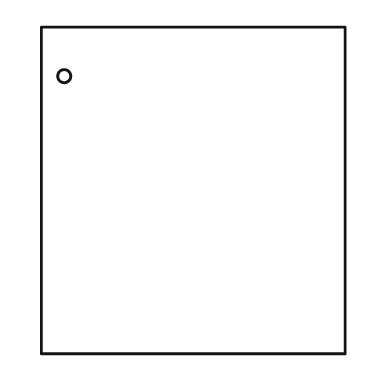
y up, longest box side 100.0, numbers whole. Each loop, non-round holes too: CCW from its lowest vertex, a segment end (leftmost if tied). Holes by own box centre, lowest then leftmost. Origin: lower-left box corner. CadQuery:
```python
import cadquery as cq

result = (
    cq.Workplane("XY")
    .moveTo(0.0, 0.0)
    .lineTo(93.0, 0.0)
    .lineTo(93.0, 100.0)
    .lineTo(0.0, 100.0)
    .close()
    .moveTo(7.0, 85.0)
    .circle(2.0)
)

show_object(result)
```